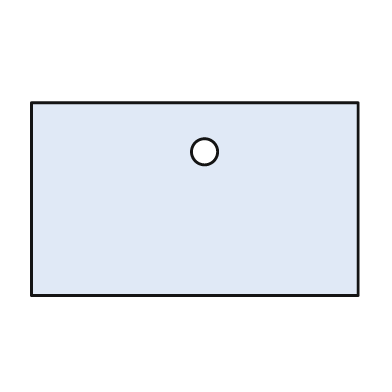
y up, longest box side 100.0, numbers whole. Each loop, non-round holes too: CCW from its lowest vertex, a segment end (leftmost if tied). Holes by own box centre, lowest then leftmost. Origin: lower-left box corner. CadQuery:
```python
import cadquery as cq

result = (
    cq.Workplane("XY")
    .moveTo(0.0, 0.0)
    .lineTo(100.0, 0.0)
    .lineTo(100.0, 59.0)
    .lineTo(0.0, 59.0)
    .close()
    .moveTo(53.0, 44.0)
    .circle(4.0)
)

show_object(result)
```